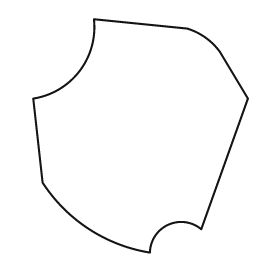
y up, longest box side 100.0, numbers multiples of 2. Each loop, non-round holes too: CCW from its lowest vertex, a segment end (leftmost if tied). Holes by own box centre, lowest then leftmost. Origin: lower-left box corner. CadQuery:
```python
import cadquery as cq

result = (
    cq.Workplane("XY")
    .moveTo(50.0, 0.0)
    .threePointArc((58.0, 12.0), (72.0, 10.0))
    .lineTo(92.0, 66.0)
    .lineTo(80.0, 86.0)
    .threePointArc((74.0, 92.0), (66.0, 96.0))
    .lineTo(26.0, 100.0)
    .threePointArc((20.0, 78.0), (0.0, 66.0))
    .lineTo(4.0, 30.0)
    .threePointArc((24.0, 10.0), (50.0, 0.0))
    .close()
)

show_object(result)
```